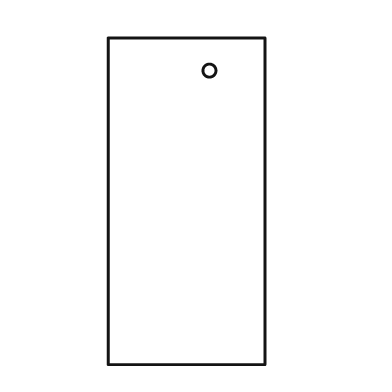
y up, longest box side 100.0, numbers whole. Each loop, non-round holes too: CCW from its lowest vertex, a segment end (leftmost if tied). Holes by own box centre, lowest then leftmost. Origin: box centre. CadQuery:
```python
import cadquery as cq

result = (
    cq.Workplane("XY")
    .moveTo(-24.0, -50.0)
    .lineTo(24.0, -50.0)
    .lineTo(24.0, 50.0)
    .lineTo(-24.0, 50.0)
    .close()
    .moveTo(7.0, 40.0)
    .circle(2.0)
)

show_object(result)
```